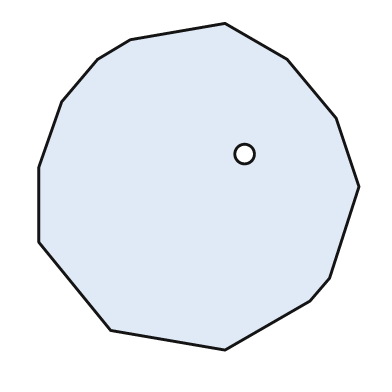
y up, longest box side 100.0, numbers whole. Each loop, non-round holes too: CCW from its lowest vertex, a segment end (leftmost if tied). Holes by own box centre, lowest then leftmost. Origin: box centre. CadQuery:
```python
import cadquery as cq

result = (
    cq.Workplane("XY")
    .moveTo(8.0, -50.0)
    .lineTo(34.0, -35.0)
    .lineTo(40.0, -28.0)
    .lineTo(49.0, 0.0)
    .lineTo(42.0, 21.0)
    .lineTo(27.0, 39.0)
    .lineTo(8.0, 50.0)
    .lineTo(-21.0, 45.0)
    .lineTo(-31.0, 39.0)
    .lineTo(-42.0, 26.0)
    .lineTo(-49.0, 6.0)
    .lineTo(-49.0, -17.0)
    .lineTo(-27.0, -44.0)
    .close()
    .moveTo(14.0, 10.0)
    .circle(3.0)
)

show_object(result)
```